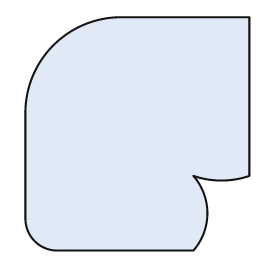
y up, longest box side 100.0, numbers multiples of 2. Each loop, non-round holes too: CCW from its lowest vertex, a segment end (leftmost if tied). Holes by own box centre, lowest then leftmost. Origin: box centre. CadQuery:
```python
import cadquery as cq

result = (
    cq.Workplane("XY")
    .moveTo(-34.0, -50.0)
    .lineTo(24.0, -50.0)
    .threePointArc((30.0, -34.0), (24.0, -18.0))
    .threePointArc((36.0, -20.0), (48.0, -18.0))
    .lineTo(48.0, 50.0)
    .lineTo(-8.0, 50.0)
    .threePointArc((-36.0, 38.0), (-48.0, 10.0))
    .lineTo(-48.0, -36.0)
    .threePointArc((-44.0, -46.0), (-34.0, -50.0))
    .close()
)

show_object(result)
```